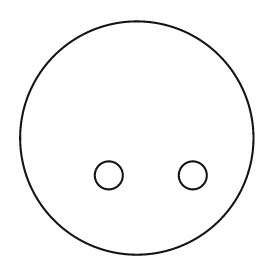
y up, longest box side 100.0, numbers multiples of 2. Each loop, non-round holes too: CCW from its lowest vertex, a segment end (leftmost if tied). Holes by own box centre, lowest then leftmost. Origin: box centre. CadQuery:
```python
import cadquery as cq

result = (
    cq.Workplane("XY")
    .moveTo(0.0, 0.0)
    .circle(50.0)
    .moveTo(-12.0, -16.0)
    .circle(6.0)
    .moveTo(24.0, -16.0)
    .circle(6.0)
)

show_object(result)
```